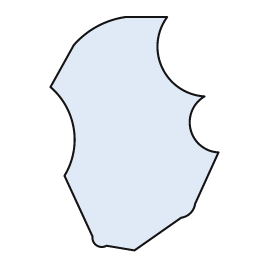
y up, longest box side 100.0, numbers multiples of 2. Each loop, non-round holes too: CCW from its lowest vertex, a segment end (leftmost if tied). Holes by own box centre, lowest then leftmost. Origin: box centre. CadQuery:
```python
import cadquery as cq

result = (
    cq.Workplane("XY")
    .moveTo(0.0, -50.0)
    .lineTo(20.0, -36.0)
    .threePointArc((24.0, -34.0), (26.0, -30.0))
    .lineTo(36.0, -8.0)
    .threePointArc((24.0, 2.0), (30.0, 16.0))
    .threePointArc((12.0, 28.0), (14.0, 50.0))
    .lineTo(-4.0, 50.0)
    .threePointArc((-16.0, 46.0), (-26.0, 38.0))
    .lineTo(-36.0, 20.0)
    .threePointArc((-26.0, 2.0), (-30.0, -18.0))
    .lineTo(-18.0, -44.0)
    .threePointArc((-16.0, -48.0), (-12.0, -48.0))
    .close()
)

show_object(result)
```